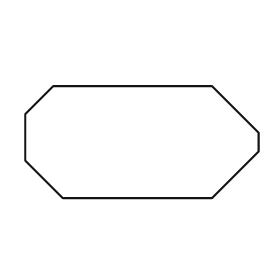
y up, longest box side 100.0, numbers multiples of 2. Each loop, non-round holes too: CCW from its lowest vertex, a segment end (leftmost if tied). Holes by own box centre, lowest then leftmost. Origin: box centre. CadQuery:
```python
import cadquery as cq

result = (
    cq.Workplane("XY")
    .moveTo(-34.0, -24.0)
    .lineTo(30.0, -24.0)
    .lineTo(50.0, -4.0)
    .lineTo(50.0, 4.0)
    .lineTo(30.0, 24.0)
    .lineTo(-38.0, 24.0)
    .lineTo(-50.0, 12.0)
    .lineTo(-50.0, -8.0)
    .close()
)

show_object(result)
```